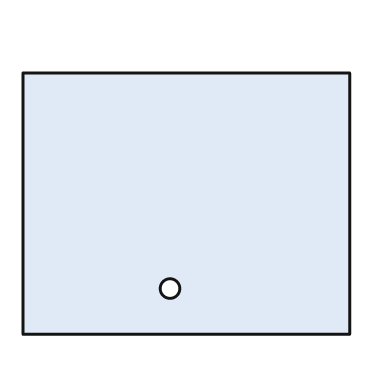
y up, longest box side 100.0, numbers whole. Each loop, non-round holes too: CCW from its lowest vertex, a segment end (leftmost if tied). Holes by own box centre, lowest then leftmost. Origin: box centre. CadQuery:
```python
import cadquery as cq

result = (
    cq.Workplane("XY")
    .moveTo(-50.0, -40.0)
    .lineTo(50.0, -40.0)
    .lineTo(50.0, 40.0)
    .lineTo(-50.0, 40.0)
    .close()
    .moveTo(-5.0, -26.0)
    .circle(3.0)
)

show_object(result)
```